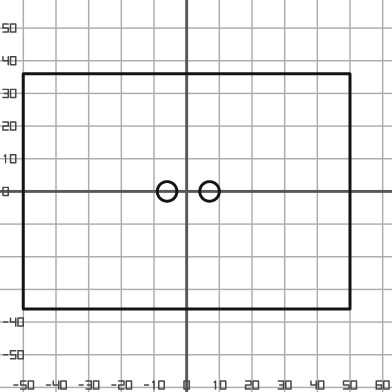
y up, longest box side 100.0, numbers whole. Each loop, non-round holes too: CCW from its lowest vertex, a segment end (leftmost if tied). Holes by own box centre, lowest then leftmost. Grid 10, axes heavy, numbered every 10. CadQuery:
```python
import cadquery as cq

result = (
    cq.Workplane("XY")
    .moveTo(-50.0, -36.0)
    .lineTo(50.0, -36.0)
    .lineTo(50.0, 36.0)
    .lineTo(-50.0, 36.0)
    .close()
    .moveTo(-6.0, 0.0)
    .circle(3.0)
    .moveTo(7.0, 0.0)
    .circle(3.0)
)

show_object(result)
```